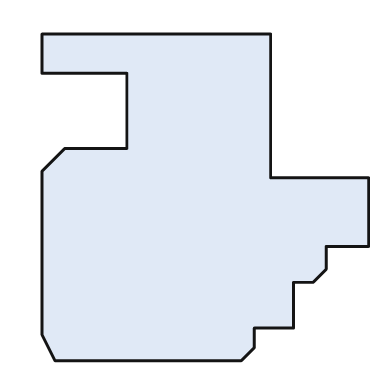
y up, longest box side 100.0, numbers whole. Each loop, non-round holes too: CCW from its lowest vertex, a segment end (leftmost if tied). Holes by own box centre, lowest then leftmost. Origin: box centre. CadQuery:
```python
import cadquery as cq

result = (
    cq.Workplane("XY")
    .moveTo(-46.0, -50.0)
    .lineTo(11.0, -50.0)
    .lineTo(15.0, -46.0)
    .lineTo(15.0, -40.0)
    .lineTo(27.0, -40.0)
    .lineTo(27.0, -26.0)
    .lineTo(33.0, -26.0)
    .lineTo(37.0, -22.0)
    .lineTo(37.0, -15.0)
    .lineTo(50.0, -15.0)
    .lineTo(50.0, 6.0)
    .lineTo(20.0, 6.0)
    .lineTo(20.0, 50.0)
    .lineTo(-50.0, 50.0)
    .lineTo(-50.0, 38.0)
    .lineTo(-24.0, 38.0)
    .lineTo(-24.0, 15.0)
    .lineTo(-43.0, 15.0)
    .lineTo(-50.0, 8.0)
    .lineTo(-50.0, -42.0)
    .close()
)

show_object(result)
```